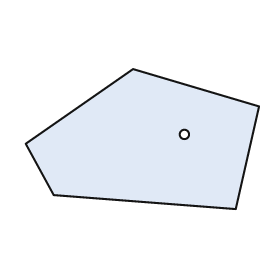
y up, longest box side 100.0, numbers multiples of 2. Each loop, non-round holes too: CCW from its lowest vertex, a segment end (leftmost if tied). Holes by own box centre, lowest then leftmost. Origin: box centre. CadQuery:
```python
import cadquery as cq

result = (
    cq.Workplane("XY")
    .moveTo(40.0, -30.0)
    .lineTo(50.0, 14.0)
    .lineTo(-4.0, 30.0)
    .lineTo(-50.0, -2.0)
    .lineTo(-38.0, -24.0)
    .close()
    .moveTo(18.0, 2.0)
    .circle(2.0)
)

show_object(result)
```